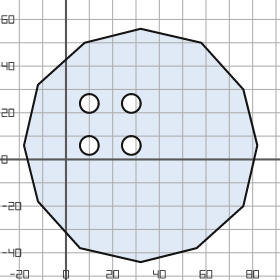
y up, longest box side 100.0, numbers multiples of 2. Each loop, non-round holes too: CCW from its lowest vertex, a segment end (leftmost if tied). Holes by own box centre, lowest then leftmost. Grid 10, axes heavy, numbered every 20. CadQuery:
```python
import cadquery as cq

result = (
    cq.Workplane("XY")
    .moveTo(32.0, -44.0)
    .lineTo(56.0, -38.0)
    .lineTo(76.0, -20.0)
    .lineTo(82.0, 6.0)
    .lineTo(76.0, 30.0)
    .lineTo(58.0, 50.0)
    .lineTo(32.0, 56.0)
    .lineTo(8.0, 50.0)
    .lineTo(-12.0, 32.0)
    .lineTo(-18.0, 6.0)
    .lineTo(-12.0, -18.0)
    .lineTo(6.0, -38.0)
    .close()
    .moveTo(10.0, 6.0)
    .circle(4.0)
    .moveTo(28.0, 6.0)
    .circle(4.0)
    .moveTo(10.0, 24.0)
    .circle(4.0)
    .moveTo(28.0, 24.0)
    .circle(4.0)
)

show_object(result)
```